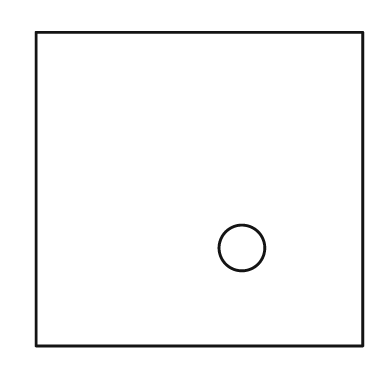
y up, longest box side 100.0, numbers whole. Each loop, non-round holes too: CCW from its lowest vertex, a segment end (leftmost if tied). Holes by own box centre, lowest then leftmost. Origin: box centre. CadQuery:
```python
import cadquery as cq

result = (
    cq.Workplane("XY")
    .moveTo(-50.0, -48.0)
    .lineTo(50.0, -48.0)
    .lineTo(50.0, 48.0)
    .lineTo(-50.0, 48.0)
    .close()
    .moveTo(13.0, -18.0)
    .circle(7.0)
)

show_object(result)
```